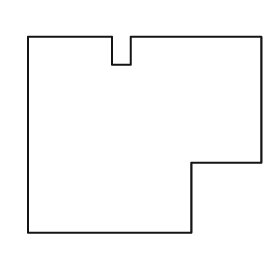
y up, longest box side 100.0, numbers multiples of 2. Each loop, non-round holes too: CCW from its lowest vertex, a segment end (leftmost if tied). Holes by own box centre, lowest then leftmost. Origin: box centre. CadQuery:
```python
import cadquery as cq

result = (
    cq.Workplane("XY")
    .moveTo(-50.0, -42.0)
    .lineTo(20.0, -42.0)
    .lineTo(20.0, -12.0)
    .lineTo(50.0, -12.0)
    .lineTo(50.0, 42.0)
    .lineTo(-6.0, 42.0)
    .lineTo(-6.0, 30.0)
    .lineTo(-14.0, 30.0)
    .lineTo(-14.0, 42.0)
    .lineTo(-50.0, 42.0)
    .close()
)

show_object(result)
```